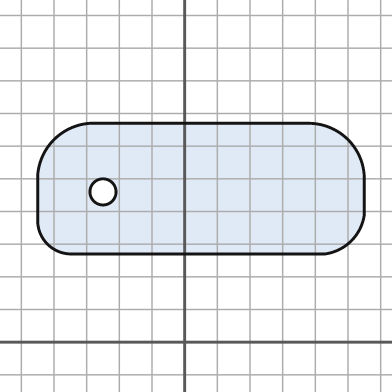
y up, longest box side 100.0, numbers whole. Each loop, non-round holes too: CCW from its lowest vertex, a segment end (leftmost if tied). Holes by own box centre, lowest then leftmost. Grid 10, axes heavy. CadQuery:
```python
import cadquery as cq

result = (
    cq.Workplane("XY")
    .moveTo(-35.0, 27.0)
    .lineTo(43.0, 27.0)
    .threePointArc((51.0, 31.0), (55.0, 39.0))
    .lineTo(55.0, 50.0)
    .threePointArc((50.0, 62.0), (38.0, 67.0))
    .lineTo(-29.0, 67.0)
    .threePointArc((-40.0, 62.0), (-45.0, 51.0))
    .lineTo(-45.0, 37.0)
    .threePointArc((-42.0, 30.0), (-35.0, 27.0))
    .close()
    .moveTo(-25.0, 46.0)
    .circle(4.0)
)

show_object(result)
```